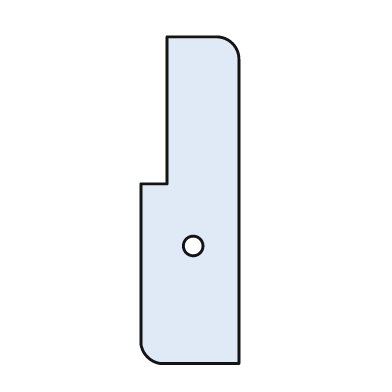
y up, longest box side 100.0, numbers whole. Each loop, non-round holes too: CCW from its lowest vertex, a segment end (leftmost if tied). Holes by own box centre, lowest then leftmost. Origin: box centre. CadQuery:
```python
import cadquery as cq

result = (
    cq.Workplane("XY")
    .moveTo(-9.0, -50.0)
    .lineTo(15.0, -50.0)
    .lineTo(15.0, 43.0)
    .threePointArc((13.0, 48.0), (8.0, 50.0))
    .lineTo(-7.0, 50.0)
    .lineTo(-7.0, 5.0)
    .lineTo(-15.0, 5.0)
    .lineTo(-15.0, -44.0)
    .threePointArc((-13.0, -48.0), (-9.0, -50.0))
    .close()
    .moveTo(1.0, -14.0)
    .circle(3.0)
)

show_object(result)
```